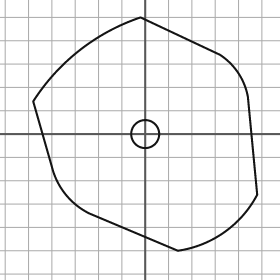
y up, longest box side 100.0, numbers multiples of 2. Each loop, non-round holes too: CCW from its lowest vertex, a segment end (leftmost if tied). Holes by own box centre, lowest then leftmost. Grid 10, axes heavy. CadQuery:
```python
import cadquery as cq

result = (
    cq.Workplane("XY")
    .moveTo(14.0, -50.0)
    .threePointArc((34.0, -42.0), (48.0, -26.0))
    .lineTo(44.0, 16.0)
    .threePointArc((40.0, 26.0), (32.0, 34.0))
    .lineTo(-2.0, 50.0)
    .threePointArc((-28.0, 36.0), (-48.0, 14.0))
    .lineTo(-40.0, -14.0)
    .threePointArc((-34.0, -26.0), (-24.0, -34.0))
    .close()
    .moveTo(0.0, 0.0)
    .circle(6.0)
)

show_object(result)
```